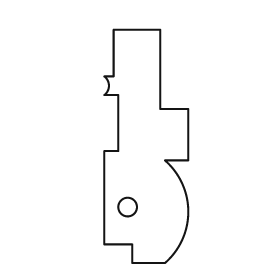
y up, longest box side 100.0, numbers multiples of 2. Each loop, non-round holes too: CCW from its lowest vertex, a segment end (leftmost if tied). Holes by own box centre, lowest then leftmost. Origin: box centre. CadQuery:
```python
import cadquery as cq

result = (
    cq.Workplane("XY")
    .moveTo(-6.0, -50.0)
    .lineTo(8.0, -50.0)
    .threePointArc((18.0, -28.0), (8.0, -6.0))
    .lineTo(18.0, -6.0)
    .lineTo(18.0, 16.0)
    .lineTo(6.0, 16.0)
    .lineTo(6.0, 50.0)
    .lineTo(-14.0, 50.0)
    .lineTo(-14.0, 30.0)
    .lineTo(-18.0, 30.0)
    .threePointArc((-16.0, 26.0), (-18.0, 22.0))
    .lineTo(-12.0, 22.0)
    .lineTo(-12.0, -2.0)
    .lineTo(-18.0, -2.0)
    .lineTo(-18.0, -42.0)
    .lineTo(-6.0, -42.0)
    .close()
    .moveTo(-8.0, -26.0)
    .circle(4.0)
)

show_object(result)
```